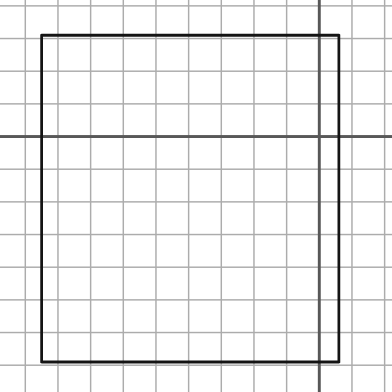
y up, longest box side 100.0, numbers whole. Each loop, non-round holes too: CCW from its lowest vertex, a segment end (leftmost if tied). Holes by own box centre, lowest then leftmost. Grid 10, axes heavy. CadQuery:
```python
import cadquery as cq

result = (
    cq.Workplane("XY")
    .moveTo(-85.0, -69.0)
    .lineTo(6.0, -69.0)
    .lineTo(6.0, 31.0)
    .lineTo(-85.0, 31.0)
    .close()
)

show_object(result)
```